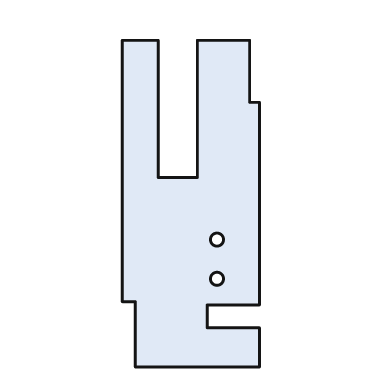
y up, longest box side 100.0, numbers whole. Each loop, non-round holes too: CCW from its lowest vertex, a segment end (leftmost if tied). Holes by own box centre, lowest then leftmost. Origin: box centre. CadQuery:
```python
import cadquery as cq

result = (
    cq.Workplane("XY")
    .moveTo(-17.0, -50.0)
    .lineTo(21.0, -50.0)
    .lineTo(21.0, -38.0)
    .lineTo(5.0, -38.0)
    .lineTo(5.0, -31.0)
    .lineTo(21.0, -31.0)
    .lineTo(21.0, 31.0)
    .lineTo(18.0, 31.0)
    .lineTo(18.0, 50.0)
    .lineTo(2.0, 50.0)
    .lineTo(2.0, 8.0)
    .lineTo(-10.0, 8.0)
    .lineTo(-10.0, 50.0)
    .lineTo(-21.0, 50.0)
    .lineTo(-21.0, -30.0)
    .lineTo(-17.0, -30.0)
    .close()
    .moveTo(8.0, -23.0)
    .circle(2.0)
    .moveTo(8.0, -11.0)
    .circle(2.0)
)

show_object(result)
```